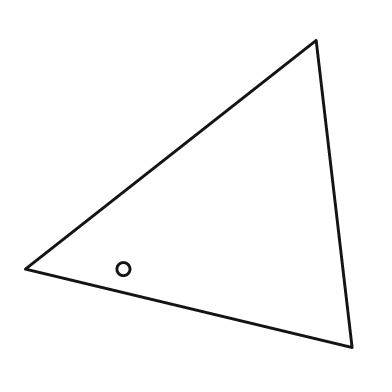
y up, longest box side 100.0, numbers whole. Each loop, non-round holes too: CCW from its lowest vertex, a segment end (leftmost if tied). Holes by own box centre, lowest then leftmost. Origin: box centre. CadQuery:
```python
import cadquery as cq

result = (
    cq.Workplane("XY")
    .moveTo(50.0, -47.0)
    .lineTo(39.0, 47.0)
    .lineTo(-50.0, -23.0)
    .close()
    .moveTo(-20.0, -23.0)
    .circle(2.0)
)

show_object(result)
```